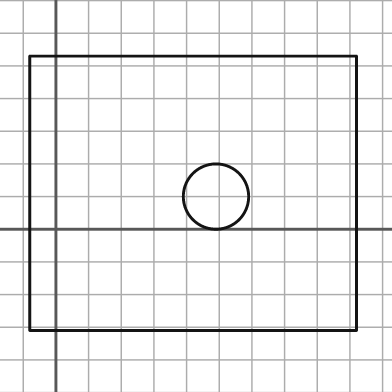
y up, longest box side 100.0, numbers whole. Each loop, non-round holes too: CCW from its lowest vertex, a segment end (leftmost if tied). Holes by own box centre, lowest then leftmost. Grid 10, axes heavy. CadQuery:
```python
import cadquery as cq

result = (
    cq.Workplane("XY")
    .moveTo(-8.0, -31.0)
    .lineTo(92.0, -31.0)
    .lineTo(92.0, 53.0)
    .lineTo(-8.0, 53.0)
    .close()
    .moveTo(49.0, 10.0)
    .circle(10.0)
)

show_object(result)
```